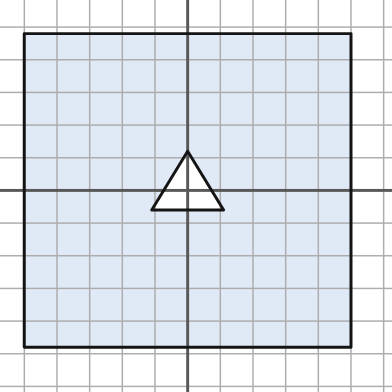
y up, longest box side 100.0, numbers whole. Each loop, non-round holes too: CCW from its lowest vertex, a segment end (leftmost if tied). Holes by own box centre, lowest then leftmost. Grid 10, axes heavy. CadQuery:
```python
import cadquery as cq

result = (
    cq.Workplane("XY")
    .moveTo(-50.0, -48.0)
    .lineTo(50.0, -48.0)
    .lineTo(50.0, 48.0)
    .lineTo(-50.0, 48.0)
    .close()
    .moveTo(-11.0, -6.0)
    .lineTo(11.0, -6.0)
    .lineTo(0.0, 12.0)
    .close()
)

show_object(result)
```